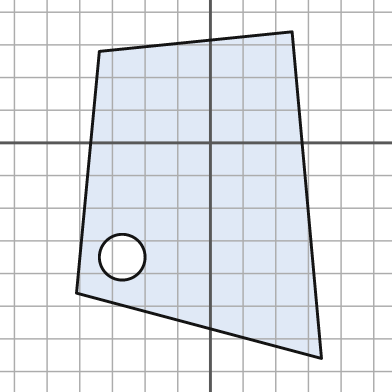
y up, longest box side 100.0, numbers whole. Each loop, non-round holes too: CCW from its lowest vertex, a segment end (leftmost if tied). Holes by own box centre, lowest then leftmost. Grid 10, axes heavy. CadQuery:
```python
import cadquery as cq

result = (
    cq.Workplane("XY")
    .moveTo(34.0, -66.0)
    .lineTo(25.0, 34.0)
    .lineTo(-34.0, 28.0)
    .lineTo(-41.0, -46.0)
    .close()
    .moveTo(-27.0, -35.0)
    .circle(7.0)
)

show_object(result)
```